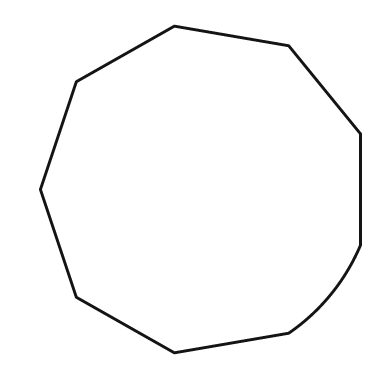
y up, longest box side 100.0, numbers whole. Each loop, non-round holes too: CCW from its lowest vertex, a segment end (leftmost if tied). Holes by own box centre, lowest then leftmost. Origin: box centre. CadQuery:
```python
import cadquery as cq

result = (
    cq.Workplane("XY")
    .moveTo(-8.0, -50.0)
    .lineTo(27.0, -44.0)
    .threePointArc((40.0, -32.0), (49.0, -17.0))
    .lineTo(49.0, 17.0)
    .lineTo(27.0, 44.0)
    .lineTo(-8.0, 50.0)
    .lineTo(-38.0, 33.0)
    .lineTo(-49.0, 0.0)
    .lineTo(-38.0, -33.0)
    .close()
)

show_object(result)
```